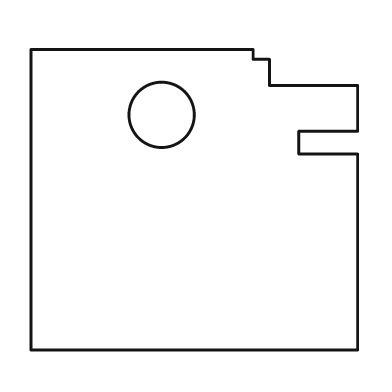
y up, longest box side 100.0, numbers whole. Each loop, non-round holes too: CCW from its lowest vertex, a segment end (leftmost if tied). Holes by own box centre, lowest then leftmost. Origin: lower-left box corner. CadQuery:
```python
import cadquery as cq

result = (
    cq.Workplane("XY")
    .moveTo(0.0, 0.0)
    .lineTo(100.0, 0.0)
    .lineTo(100.0, 60.0)
    .lineTo(82.0, 60.0)
    .lineTo(82.0, 67.0)
    .lineTo(100.0, 67.0)
    .lineTo(100.0, 81.0)
    .lineTo(73.0, 81.0)
    .lineTo(73.0, 89.0)
    .lineTo(68.0, 89.0)
    .lineTo(68.0, 92.0)
    .lineTo(0.0, 92.0)
    .close()
    .moveTo(40.0, 72.0)
    .circle(10.0)
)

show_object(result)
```